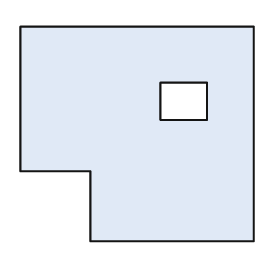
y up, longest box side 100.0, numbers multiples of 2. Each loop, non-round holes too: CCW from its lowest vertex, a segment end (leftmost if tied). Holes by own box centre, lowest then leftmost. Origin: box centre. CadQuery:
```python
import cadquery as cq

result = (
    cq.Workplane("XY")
    .moveTo(-20.0, -46.0)
    .lineTo(50.0, -46.0)
    .lineTo(50.0, 46.0)
    .lineTo(-50.0, 46.0)
    .lineTo(-50.0, -16.0)
    .lineTo(-20.0, -16.0)
    .close()
    .moveTo(10.0, 6.0)
    .lineTo(30.0, 6.0)
    .lineTo(30.0, 22.0)
    .lineTo(10.0, 22.0)
    .close()
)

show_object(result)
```